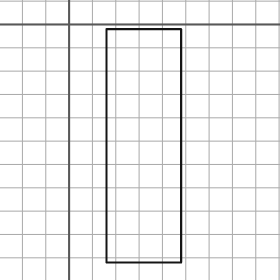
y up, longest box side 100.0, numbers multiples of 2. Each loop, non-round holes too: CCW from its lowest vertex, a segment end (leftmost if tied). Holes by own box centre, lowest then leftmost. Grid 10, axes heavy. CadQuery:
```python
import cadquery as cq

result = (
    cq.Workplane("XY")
    .moveTo(16.0, -102.0)
    .lineTo(48.0, -102.0)
    .lineTo(48.0, -2.0)
    .lineTo(16.0, -2.0)
    .close()
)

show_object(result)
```